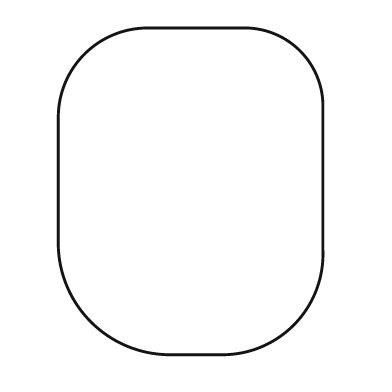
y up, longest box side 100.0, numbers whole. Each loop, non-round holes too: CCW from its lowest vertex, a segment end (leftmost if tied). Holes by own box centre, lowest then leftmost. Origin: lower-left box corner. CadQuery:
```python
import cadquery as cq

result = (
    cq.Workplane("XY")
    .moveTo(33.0, 0.0)
    .lineTo(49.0, 0.0)
    .threePointArc((72.0, 9.0), (81.0, 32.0))
    .lineTo(81.0, 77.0)
    .threePointArc((74.0, 93.0), (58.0, 100.0))
    .lineTo(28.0, 100.0)
    .threePointArc((8.0, 92.0), (0.0, 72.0))
    .lineTo(0.0, 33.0)
    .threePointArc((10.0, 10.0), (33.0, 0.0))
    .close()
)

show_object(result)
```